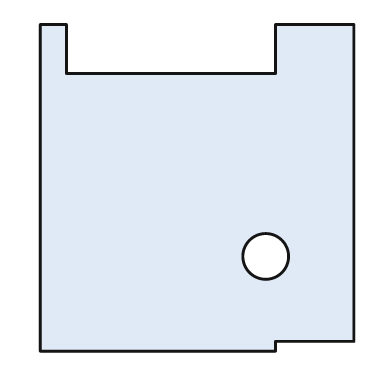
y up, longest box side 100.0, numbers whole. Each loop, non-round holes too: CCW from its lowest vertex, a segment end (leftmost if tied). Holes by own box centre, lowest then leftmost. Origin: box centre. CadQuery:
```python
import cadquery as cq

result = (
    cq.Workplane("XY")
    .moveTo(-48.0, -50.0)
    .lineTo(24.0, -50.0)
    .lineTo(24.0, -47.0)
    .lineTo(48.0, -47.0)
    .lineTo(48.0, 50.0)
    .lineTo(24.0, 50.0)
    .lineTo(24.0, 35.0)
    .lineTo(-40.0, 35.0)
    .lineTo(-40.0, 50.0)
    .lineTo(-48.0, 50.0)
    .close()
    .moveTo(21.0, -21.0)
    .circle(7.0)
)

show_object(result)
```